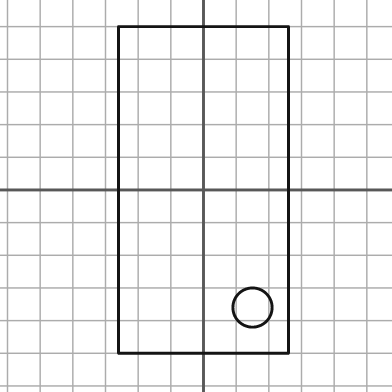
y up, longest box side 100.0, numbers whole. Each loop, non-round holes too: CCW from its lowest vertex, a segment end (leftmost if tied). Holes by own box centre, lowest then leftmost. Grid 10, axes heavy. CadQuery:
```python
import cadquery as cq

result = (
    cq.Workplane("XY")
    .moveTo(-26.0, -50.0)
    .lineTo(26.0, -50.0)
    .lineTo(26.0, 50.0)
    .lineTo(-26.0, 50.0)
    .close()
    .moveTo(15.0, -36.0)
    .circle(6.0)
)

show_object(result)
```